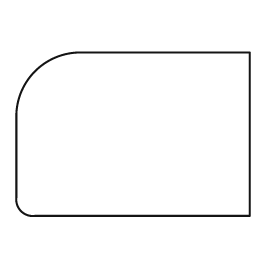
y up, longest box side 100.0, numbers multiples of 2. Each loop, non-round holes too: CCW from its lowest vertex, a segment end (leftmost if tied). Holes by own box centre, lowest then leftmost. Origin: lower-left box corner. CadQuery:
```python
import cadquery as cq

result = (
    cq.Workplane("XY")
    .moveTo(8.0, 0.0)
    .lineTo(100.0, 0.0)
    .lineTo(100.0, 70.0)
    .lineTo(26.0, 70.0)
    .threePointArc((8.0, 62.0), (0.0, 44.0))
    .lineTo(0.0, 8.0)
    .threePointArc((2.0, 2.0), (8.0, 0.0))
    .close()
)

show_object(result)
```